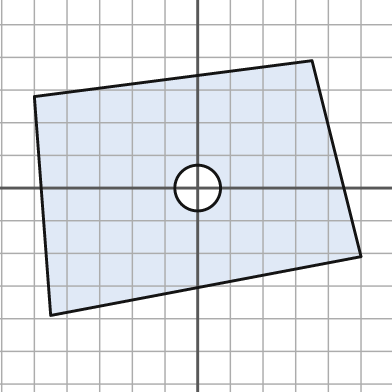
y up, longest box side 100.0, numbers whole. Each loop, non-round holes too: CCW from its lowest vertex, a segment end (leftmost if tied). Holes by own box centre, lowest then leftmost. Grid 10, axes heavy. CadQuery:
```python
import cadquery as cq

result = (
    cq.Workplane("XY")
    .moveTo(-45.0, -39.0)
    .lineTo(50.0, -21.0)
    .lineTo(35.0, 39.0)
    .lineTo(-50.0, 28.0)
    .close()
    .moveTo(0.0, 0.0)
    .circle(7.0)
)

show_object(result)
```